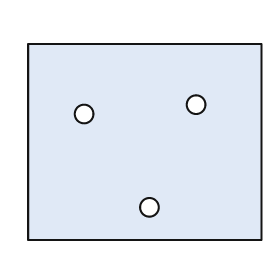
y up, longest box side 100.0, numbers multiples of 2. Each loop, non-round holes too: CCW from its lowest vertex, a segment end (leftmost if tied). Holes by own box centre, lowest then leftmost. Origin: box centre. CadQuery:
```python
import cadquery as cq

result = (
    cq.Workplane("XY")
    .moveTo(-50.0, -42.0)
    .lineTo(50.0, -42.0)
    .lineTo(50.0, 42.0)
    .lineTo(-50.0, 42.0)
    .close()
    .moveTo(2.0, -28.0)
    .circle(4.0)
    .moveTo(-26.0, 12.0)
    .circle(4.0)
    .moveTo(22.0, 16.0)
    .circle(4.0)
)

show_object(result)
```